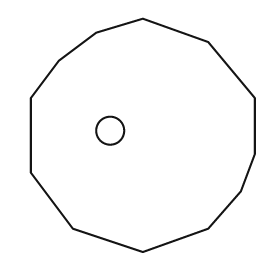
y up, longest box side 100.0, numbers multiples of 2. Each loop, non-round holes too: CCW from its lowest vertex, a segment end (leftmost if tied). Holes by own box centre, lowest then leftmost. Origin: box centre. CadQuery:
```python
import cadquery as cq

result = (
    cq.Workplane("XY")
    .moveTo(0.0, -50.0)
    .lineTo(28.0, -40.0)
    .lineTo(42.0, -24.0)
    .lineTo(48.0, -8.0)
    .lineTo(48.0, 16.0)
    .lineTo(28.0, 40.0)
    .lineTo(0.0, 50.0)
    .lineTo(-20.0, 44.0)
    .lineTo(-36.0, 32.0)
    .lineTo(-48.0, 16.0)
    .lineTo(-48.0, -16.0)
    .lineTo(-30.0, -40.0)
    .close()
    .moveTo(-14.0, 2.0)
    .circle(6.0)
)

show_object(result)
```